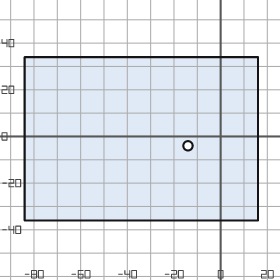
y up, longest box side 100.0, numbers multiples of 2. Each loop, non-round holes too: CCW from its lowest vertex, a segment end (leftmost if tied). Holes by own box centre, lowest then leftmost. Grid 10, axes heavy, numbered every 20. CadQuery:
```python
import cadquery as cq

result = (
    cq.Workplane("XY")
    .moveTo(-84.0, -36.0)
    .lineTo(16.0, -36.0)
    .lineTo(16.0, 34.0)
    .lineTo(-84.0, 34.0)
    .close()
    .moveTo(-14.0, -4.0)
    .circle(2.0)
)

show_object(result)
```